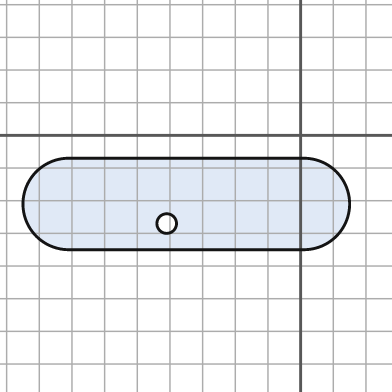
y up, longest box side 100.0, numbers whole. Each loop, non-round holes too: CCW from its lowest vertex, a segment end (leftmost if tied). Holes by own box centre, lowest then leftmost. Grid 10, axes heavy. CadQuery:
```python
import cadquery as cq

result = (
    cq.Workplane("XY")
    .moveTo(-71.0, -35.0)
    .lineTo(1.0, -35.0)
    .threePointArc((15.0, -21.0), (1.0, -7.0))
    .lineTo(-71.0, -7.0)
    .threePointArc((-85.0, -21.0), (-71.0, -35.0))
    .close()
    .moveTo(-41.0, -27.0)
    .circle(3.0)
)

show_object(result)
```